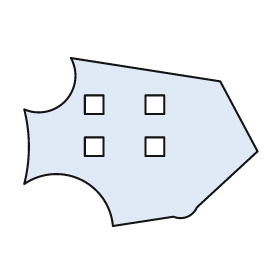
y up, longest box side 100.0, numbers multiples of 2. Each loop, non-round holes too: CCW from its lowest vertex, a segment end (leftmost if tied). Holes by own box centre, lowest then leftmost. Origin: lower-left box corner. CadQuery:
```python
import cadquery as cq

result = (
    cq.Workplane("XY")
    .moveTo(38.0, 0.0)
    .lineTo(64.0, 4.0)
    .threePointArc((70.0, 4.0), (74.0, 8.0))
    .lineTo(100.0, 32.0)
    .lineTo(84.0, 62.0)
    .lineTo(20.0, 72.0)
    .threePointArc((18.0, 54.0), (0.0, 50.0))
    .threePointArc((2.0, 34.0), (0.0, 18.0))
    .threePointArc((24.0, 20.0), (38.0, 0.0))
    .close()
    .moveTo(26.0, 30.0)
    .lineTo(34.0, 30.0)
    .lineTo(34.0, 38.0)
    .lineTo(26.0, 38.0)
    .close()
    .moveTo(52.0, 30.0)
    .lineTo(60.0, 30.0)
    .lineTo(60.0, 38.0)
    .lineTo(52.0, 38.0)
    .close()
    .moveTo(26.0, 48.0)
    .lineTo(34.0, 48.0)
    .lineTo(34.0, 56.0)
    .lineTo(26.0, 56.0)
    .close()
    .moveTo(52.0, 48.0)
    .lineTo(60.0, 48.0)
    .lineTo(60.0, 56.0)
    .lineTo(52.0, 56.0)
    .close()
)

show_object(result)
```